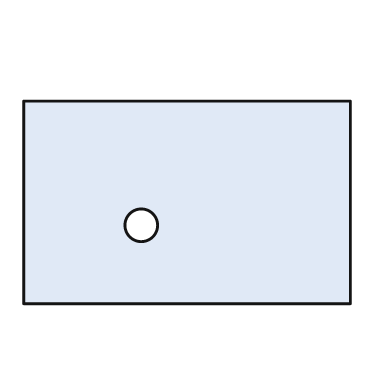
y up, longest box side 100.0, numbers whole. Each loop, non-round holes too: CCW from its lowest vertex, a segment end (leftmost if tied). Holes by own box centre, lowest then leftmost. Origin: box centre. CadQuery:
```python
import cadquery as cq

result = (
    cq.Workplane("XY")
    .moveTo(-50.0, -31.0)
    .lineTo(50.0, -31.0)
    .lineTo(50.0, 31.0)
    .lineTo(-50.0, 31.0)
    .close()
    .moveTo(-14.0, -7.0)
    .circle(5.0)
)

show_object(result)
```